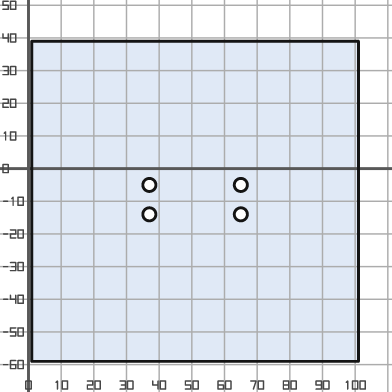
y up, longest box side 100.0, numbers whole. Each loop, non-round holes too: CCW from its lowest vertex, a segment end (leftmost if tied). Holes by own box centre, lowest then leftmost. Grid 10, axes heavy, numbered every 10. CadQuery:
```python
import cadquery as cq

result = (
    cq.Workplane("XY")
    .moveTo(1.0, -59.0)
    .lineTo(101.0, -59.0)
    .lineTo(101.0, 39.0)
    .lineTo(1.0, 39.0)
    .close()
    .moveTo(37.0, -14.0)
    .circle(2.0)
    .moveTo(65.0, -14.0)
    .circle(2.0)
    .moveTo(37.0, -5.0)
    .circle(2.0)
    .moveTo(65.0, -5.0)
    .circle(2.0)
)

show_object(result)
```